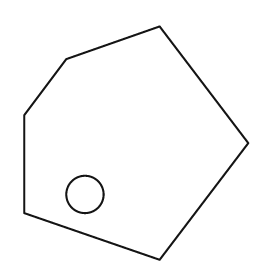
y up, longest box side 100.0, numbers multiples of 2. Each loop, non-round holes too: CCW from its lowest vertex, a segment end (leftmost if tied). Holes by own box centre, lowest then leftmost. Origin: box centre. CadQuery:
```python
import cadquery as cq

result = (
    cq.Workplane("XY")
    .moveTo(10.0, -50.0)
    .lineTo(48.0, 0.0)
    .lineTo(10.0, 50.0)
    .lineTo(-30.0, 36.0)
    .lineTo(-48.0, 12.0)
    .lineTo(-48.0, -30.0)
    .close()
    .moveTo(-22.0, -22.0)
    .circle(8.0)
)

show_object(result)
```